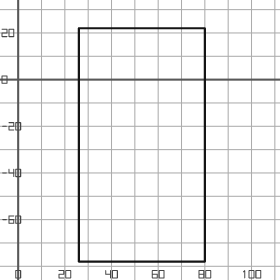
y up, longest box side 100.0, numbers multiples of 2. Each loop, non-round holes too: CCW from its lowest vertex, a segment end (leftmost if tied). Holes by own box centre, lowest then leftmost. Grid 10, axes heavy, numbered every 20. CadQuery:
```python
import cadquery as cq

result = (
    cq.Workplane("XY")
    .moveTo(26.0, -78.0)
    .lineTo(80.0, -78.0)
    .lineTo(80.0, 22.0)
    .lineTo(26.0, 22.0)
    .close()
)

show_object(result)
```